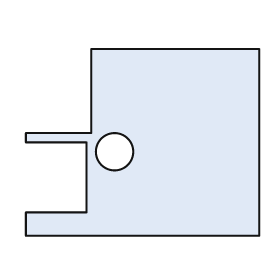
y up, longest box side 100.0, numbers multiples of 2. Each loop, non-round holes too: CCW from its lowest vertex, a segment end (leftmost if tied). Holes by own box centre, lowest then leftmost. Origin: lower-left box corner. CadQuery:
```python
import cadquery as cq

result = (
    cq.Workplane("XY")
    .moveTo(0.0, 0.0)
    .lineTo(100.0, 0.0)
    .lineTo(100.0, 80.0)
    .lineTo(28.0, 80.0)
    .lineTo(28.0, 44.0)
    .lineTo(0.0, 44.0)
    .lineTo(0.0, 40.0)
    .lineTo(26.0, 40.0)
    .lineTo(26.0, 10.0)
    .lineTo(0.0, 10.0)
    .close()
    .moveTo(38.0, 36.0)
    .circle(8.0)
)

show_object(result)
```